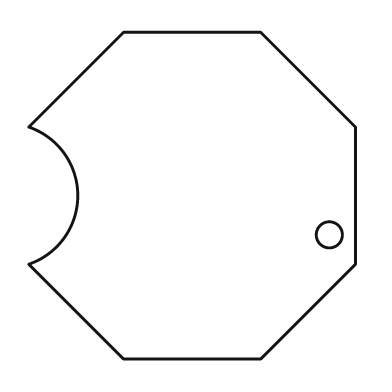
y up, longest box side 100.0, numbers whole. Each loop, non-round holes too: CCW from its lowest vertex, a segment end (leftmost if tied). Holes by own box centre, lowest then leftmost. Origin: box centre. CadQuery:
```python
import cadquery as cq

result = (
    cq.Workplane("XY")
    .moveTo(-21.0, -50.0)
    .lineTo(21.0, -50.0)
    .lineTo(50.0, -21.0)
    .lineTo(50.0, 21.0)
    .lineTo(21.0, 50.0)
    .lineTo(-21.0, 50.0)
    .lineTo(-50.0, 21.0)
    .threePointArc((-35.0, 0.0), (-50.0, -21.0))
    .close()
    .moveTo(42.0, -12.0)
    .circle(4.0)
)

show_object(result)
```